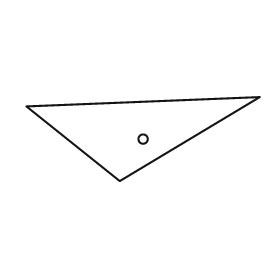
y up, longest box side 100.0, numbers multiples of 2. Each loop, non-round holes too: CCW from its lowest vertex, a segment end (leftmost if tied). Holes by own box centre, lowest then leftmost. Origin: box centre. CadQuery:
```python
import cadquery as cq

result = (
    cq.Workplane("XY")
    .moveTo(-10.0, -18.0)
    .lineTo(50.0, 18.0)
    .lineTo(-50.0, 14.0)
    .close()
    .moveTo(0.0, 0.0)
    .circle(2.0)
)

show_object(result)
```